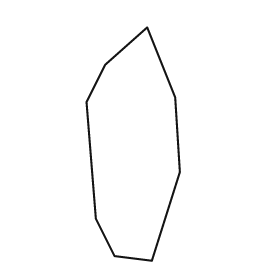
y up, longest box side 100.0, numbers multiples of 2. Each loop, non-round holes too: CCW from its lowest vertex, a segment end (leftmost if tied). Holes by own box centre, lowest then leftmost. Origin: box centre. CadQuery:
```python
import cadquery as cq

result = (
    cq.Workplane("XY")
    .moveTo(8.0, -50.0)
    .lineTo(20.0, -12.0)
    .lineTo(18.0, 20.0)
    .lineTo(6.0, 50.0)
    .lineTo(-12.0, 34.0)
    .lineTo(-20.0, 18.0)
    .lineTo(-16.0, -32.0)
    .lineTo(-8.0, -48.0)
    .close()
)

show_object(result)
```